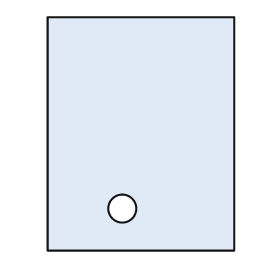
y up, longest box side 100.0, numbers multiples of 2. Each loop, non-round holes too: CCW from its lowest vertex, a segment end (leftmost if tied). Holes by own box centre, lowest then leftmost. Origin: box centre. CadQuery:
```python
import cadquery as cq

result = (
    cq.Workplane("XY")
    .moveTo(-40.0, -50.0)
    .lineTo(40.0, -50.0)
    .lineTo(40.0, 50.0)
    .lineTo(-40.0, 50.0)
    .close()
    .moveTo(-8.0, -32.0)
    .circle(6.0)
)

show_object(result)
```